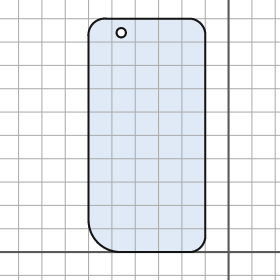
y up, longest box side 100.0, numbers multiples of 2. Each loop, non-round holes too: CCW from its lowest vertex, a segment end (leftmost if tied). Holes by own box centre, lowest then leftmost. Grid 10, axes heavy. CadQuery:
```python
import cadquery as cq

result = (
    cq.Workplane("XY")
    .moveTo(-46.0, 0.0)
    .lineTo(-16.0, 0.0)
    .threePointArc((-12.0, 2.0), (-10.0, 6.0))
    .lineTo(-10.0, 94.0)
    .threePointArc((-12.0, 98.0), (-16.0, 100.0))
    .lineTo(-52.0, 100.0)
    .threePointArc((-58.0, 98.0), (-60.0, 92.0))
    .lineTo(-60.0, 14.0)
    .threePointArc((-56.0, 4.0), (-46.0, 0.0))
    .close()
    .moveTo(-46.0, 94.0)
    .circle(2.0)
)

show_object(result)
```